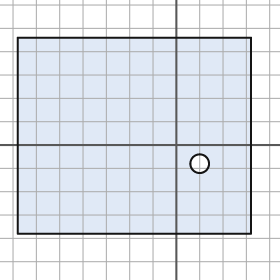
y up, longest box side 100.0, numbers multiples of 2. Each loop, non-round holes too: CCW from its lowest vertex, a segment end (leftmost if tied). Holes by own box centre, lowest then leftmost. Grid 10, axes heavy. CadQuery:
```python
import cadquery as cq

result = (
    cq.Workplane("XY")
    .moveTo(-68.0, -38.0)
    .lineTo(32.0, -38.0)
    .lineTo(32.0, 46.0)
    .lineTo(-68.0, 46.0)
    .close()
    .moveTo(10.0, -8.0)
    .circle(4.0)
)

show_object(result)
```